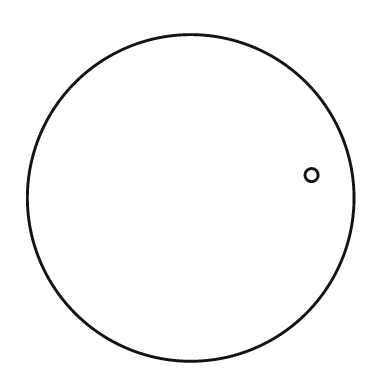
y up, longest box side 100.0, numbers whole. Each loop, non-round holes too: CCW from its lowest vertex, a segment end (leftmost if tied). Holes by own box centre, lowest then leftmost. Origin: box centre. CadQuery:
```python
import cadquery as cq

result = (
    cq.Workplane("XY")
    .moveTo(0.0, 0.0)
    .circle(50.0)
    .moveTo(37.0, 7.0)
    .circle(2.0)
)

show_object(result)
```